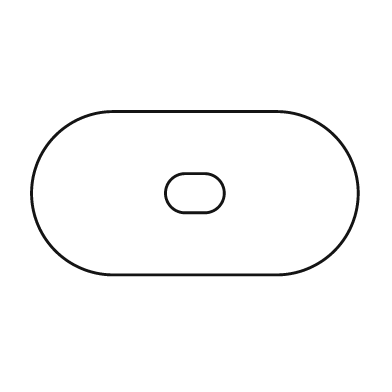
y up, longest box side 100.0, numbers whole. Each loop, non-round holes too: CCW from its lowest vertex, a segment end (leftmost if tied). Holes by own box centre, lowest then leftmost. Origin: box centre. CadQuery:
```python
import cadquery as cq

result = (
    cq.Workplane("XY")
    .moveTo(-25.0, -25.0)
    .lineTo(25.0, -25.0)
    .threePointArc((50.0, 0.0), (25.0, 25.0))
    .lineTo(-25.0, 25.0)
    .threePointArc((-50.0, 0.0), (-25.0, -25.0))
    .close()
    .moveTo(-3.0, -6.0)
    .lineTo(3.0, -6.0)
    .threePointArc((9.0, 0.0), (3.0, 6.0))
    .lineTo(-3.0, 6.0)
    .threePointArc((-9.0, 0.0), (-3.0, -6.0))
    .close()
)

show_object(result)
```